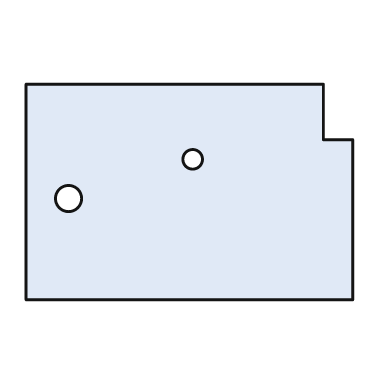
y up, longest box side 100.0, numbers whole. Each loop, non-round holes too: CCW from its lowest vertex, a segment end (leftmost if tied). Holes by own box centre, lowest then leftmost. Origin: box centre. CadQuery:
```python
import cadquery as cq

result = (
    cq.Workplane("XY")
    .moveTo(-50.0, -33.0)
    .lineTo(50.0, -33.0)
    .lineTo(50.0, 16.0)
    .lineTo(41.0, 16.0)
    .lineTo(41.0, 33.0)
    .lineTo(-50.0, 33.0)
    .close()
    .moveTo(-37.0, -2.0)
    .circle(4.0)
    .moveTo(1.0, 10.0)
    .circle(3.0)
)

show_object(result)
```